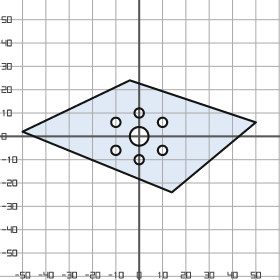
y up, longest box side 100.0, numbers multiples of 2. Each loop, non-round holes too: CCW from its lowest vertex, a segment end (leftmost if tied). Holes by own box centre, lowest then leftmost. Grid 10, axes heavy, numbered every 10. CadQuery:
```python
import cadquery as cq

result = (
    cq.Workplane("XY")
    .moveTo(14.0, -24.0)
    .lineTo(50.0, 6.0)
    .lineTo(-4.0, 24.0)
    .lineTo(-50.0, 2.0)
    .close()
    .moveTo(0.0, -10.0)
    .circle(2.0)
    .moveTo(-10.0, -6.0)
    .circle(2.0)
    .moveTo(10.0, -6.0)
    .circle(2.0)
    .moveTo(0.0, 0.0)
    .circle(4.0)
    .moveTo(-10.0, 6.0)
    .circle(2.0)
    .moveTo(10.0, 6.0)
    .circle(2.0)
    .moveTo(0.0, 10.0)
    .circle(2.0)
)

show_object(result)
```